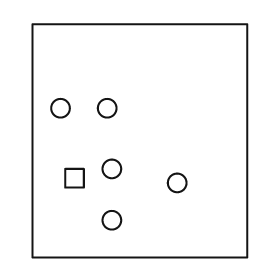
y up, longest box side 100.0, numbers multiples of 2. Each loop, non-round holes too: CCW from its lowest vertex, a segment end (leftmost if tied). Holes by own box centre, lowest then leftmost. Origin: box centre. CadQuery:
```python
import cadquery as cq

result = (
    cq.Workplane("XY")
    .moveTo(-46.0, -50.0)
    .lineTo(46.0, -50.0)
    .lineTo(46.0, 50.0)
    .lineTo(-46.0, 50.0)
    .close()
    .moveTo(-12.0, -34.0)
    .circle(4.0)
    .moveTo(16.0, -18.0)
    .circle(4.0)
    .moveTo(-32.0, -20.0)
    .lineTo(-24.0, -20.0)
    .lineTo(-24.0, -12.0)
    .lineTo(-32.0, -12.0)
    .close()
    .moveTo(-12.0, -12.0)
    .circle(4.0)
    .moveTo(-34.0, 14.0)
    .circle(4.0)
    .moveTo(-14.0, 14.0)
    .circle(4.0)
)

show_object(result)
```